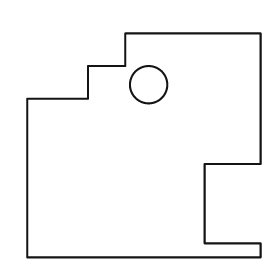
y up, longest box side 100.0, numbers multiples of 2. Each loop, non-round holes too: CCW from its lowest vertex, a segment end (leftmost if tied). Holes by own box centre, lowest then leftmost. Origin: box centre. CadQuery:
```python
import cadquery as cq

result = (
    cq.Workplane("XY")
    .moveTo(-50.0, -48.0)
    .lineTo(50.0, -48.0)
    .lineTo(50.0, -42.0)
    .lineTo(26.0, -42.0)
    .lineTo(26.0, -8.0)
    .lineTo(50.0, -8.0)
    .lineTo(50.0, 48.0)
    .lineTo(-8.0, 48.0)
    .lineTo(-8.0, 34.0)
    .lineTo(-24.0, 34.0)
    .lineTo(-24.0, 20.0)
    .lineTo(-50.0, 20.0)
    .close()
    .moveTo(2.0, 26.0)
    .circle(8.0)
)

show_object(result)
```